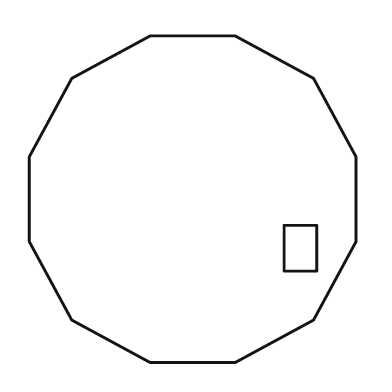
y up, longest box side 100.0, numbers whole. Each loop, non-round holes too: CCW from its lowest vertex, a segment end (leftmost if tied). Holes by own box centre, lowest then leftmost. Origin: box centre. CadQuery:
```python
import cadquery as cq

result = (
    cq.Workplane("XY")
    .moveTo(-13.0, -50.0)
    .lineTo(13.0, -50.0)
    .lineTo(37.0, -37.0)
    .lineTo(50.0, -13.0)
    .lineTo(50.0, 13.0)
    .lineTo(37.0, 37.0)
    .lineTo(13.0, 50.0)
    .lineTo(-13.0, 50.0)
    .lineTo(-37.0, 37.0)
    .lineTo(-50.0, 13.0)
    .lineTo(-50.0, -13.0)
    .lineTo(-37.0, -37.0)
    .close()
    .moveTo(28.0, -22.0)
    .lineTo(38.0, -22.0)
    .lineTo(38.0, -8.0)
    .lineTo(28.0, -8.0)
    .close()
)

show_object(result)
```